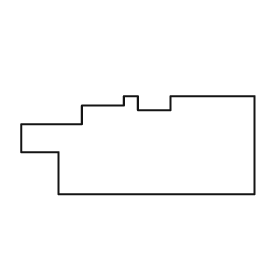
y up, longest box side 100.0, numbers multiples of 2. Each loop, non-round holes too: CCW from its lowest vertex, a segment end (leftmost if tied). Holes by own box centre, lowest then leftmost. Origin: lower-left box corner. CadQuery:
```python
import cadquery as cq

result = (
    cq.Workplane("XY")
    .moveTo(16.0, 0.0)
    .lineTo(100.0, 0.0)
    .lineTo(100.0, 42.0)
    .lineTo(64.0, 42.0)
    .lineTo(64.0, 36.0)
    .lineTo(50.0, 36.0)
    .lineTo(50.0, 42.0)
    .lineTo(44.0, 42.0)
    .lineTo(44.0, 38.0)
    .lineTo(26.0, 38.0)
    .lineTo(26.0, 30.0)
    .lineTo(0.0, 30.0)
    .lineTo(0.0, 18.0)
    .lineTo(16.0, 18.0)
    .close()
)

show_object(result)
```